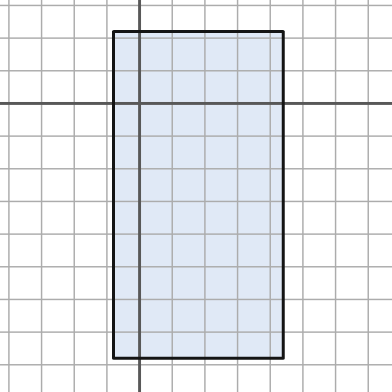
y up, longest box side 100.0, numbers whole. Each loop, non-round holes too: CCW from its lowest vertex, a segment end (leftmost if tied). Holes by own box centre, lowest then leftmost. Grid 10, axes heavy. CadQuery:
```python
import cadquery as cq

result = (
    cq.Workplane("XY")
    .moveTo(-8.0, -78.0)
    .lineTo(44.0, -78.0)
    .lineTo(44.0, 22.0)
    .lineTo(-8.0, 22.0)
    .close()
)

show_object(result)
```